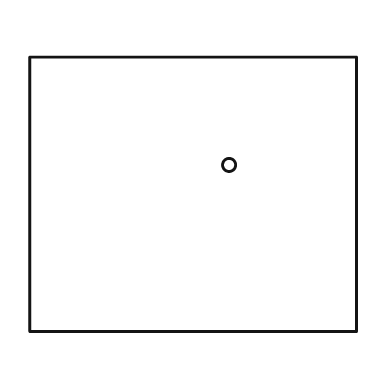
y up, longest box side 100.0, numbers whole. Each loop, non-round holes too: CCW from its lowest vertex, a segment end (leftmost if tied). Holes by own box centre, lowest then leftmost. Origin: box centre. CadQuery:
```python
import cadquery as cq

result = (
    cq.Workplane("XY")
    .moveTo(-50.0, -42.0)
    .lineTo(50.0, -42.0)
    .lineTo(50.0, 42.0)
    .lineTo(-50.0, 42.0)
    .close()
    .moveTo(11.0, 9.0)
    .circle(2.0)
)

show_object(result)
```